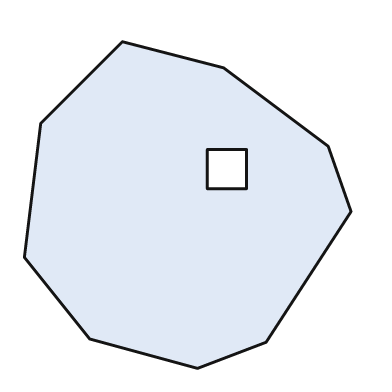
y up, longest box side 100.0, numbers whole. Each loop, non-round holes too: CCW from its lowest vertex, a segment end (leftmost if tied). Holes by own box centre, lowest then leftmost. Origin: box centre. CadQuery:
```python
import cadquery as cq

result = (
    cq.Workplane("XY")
    .moveTo(3.0, -50.0)
    .lineTo(24.0, -42.0)
    .lineTo(50.0, -2.0)
    .lineTo(43.0, 18.0)
    .lineTo(11.0, 42.0)
    .lineTo(-20.0, 50.0)
    .lineTo(-45.0, 25.0)
    .lineTo(-50.0, -16.0)
    .lineTo(-30.0, -41.0)
    .close()
    .moveTo(6.0, 5.0)
    .lineTo(18.0, 5.0)
    .lineTo(18.0, 17.0)
    .lineTo(6.0, 17.0)
    .close()
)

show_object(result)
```